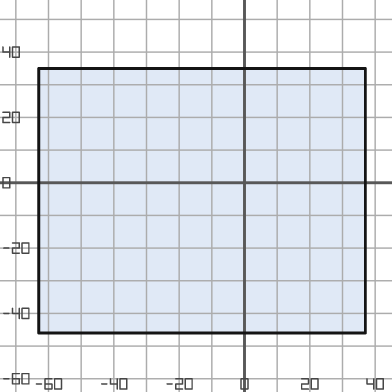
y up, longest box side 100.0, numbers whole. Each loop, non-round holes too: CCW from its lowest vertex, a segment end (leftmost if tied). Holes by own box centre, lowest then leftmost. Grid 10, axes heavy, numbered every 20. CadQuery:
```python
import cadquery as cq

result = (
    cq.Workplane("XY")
    .moveTo(-63.0, -46.0)
    .lineTo(37.0, -46.0)
    .lineTo(37.0, 35.0)
    .lineTo(-63.0, 35.0)
    .close()
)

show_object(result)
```